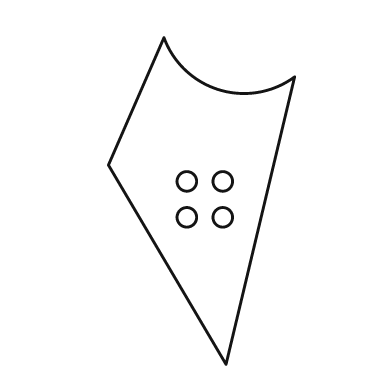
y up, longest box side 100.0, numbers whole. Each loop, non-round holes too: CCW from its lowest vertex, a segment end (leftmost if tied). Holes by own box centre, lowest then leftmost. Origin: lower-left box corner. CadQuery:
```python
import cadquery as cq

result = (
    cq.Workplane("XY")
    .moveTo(36.0, 0.0)
    .lineTo(57.0, 88.0)
    .threePointArc((34.0, 84.0), (17.0, 100.0))
    .lineTo(0.0, 61.0)
    .close()
    .moveTo(24.0, 45.0)
    .circle(3.0)
    .moveTo(35.0, 45.0)
    .circle(3.0)
    .moveTo(24.0, 56.0)
    .circle(3.0)
    .moveTo(35.0, 56.0)
    .circle(3.0)
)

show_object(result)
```